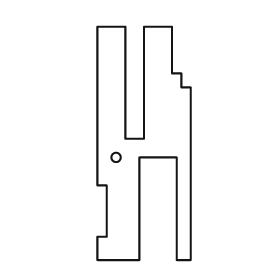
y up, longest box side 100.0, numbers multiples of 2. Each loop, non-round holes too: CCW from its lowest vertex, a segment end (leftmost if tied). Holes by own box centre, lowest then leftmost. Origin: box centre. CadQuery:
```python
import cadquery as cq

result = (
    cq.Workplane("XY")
    .moveTo(-20.0, -50.0)
    .lineTo(-2.0, -50.0)
    .lineTo(-2.0, -6.0)
    .lineTo(14.0, -6.0)
    .lineTo(14.0, -50.0)
    .lineTo(20.0, -50.0)
    .lineTo(20.0, 24.0)
    .lineTo(16.0, 24.0)
    .lineTo(16.0, 30.0)
    .lineTo(12.0, 30.0)
    .lineTo(12.0, 50.0)
    .lineTo(0.0, 50.0)
    .lineTo(0.0, 2.0)
    .lineTo(-8.0, 2.0)
    .lineTo(-8.0, 50.0)
    .lineTo(-20.0, 50.0)
    .lineTo(-20.0, -18.0)
    .lineTo(-16.0, -18.0)
    .lineTo(-16.0, -40.0)
    .lineTo(-20.0, -40.0)
    .close()
    .moveTo(-12.0, -6.0)
    .circle(2.0)
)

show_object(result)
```